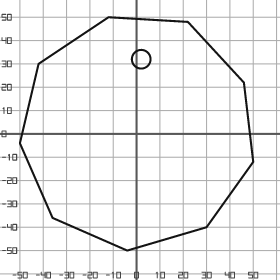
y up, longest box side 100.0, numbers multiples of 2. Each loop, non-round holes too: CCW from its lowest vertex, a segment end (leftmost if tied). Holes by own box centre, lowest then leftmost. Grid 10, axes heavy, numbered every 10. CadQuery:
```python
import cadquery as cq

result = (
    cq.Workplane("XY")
    .moveTo(-4.0, -50.0)
    .lineTo(30.0, -40.0)
    .lineTo(50.0, -12.0)
    .lineTo(46.0, 22.0)
    .lineTo(22.0, 48.0)
    .lineTo(-12.0, 50.0)
    .lineTo(-42.0, 30.0)
    .lineTo(-50.0, -4.0)
    .lineTo(-36.0, -36.0)
    .close()
    .moveTo(2.0, 32.0)
    .circle(4.0)
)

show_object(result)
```